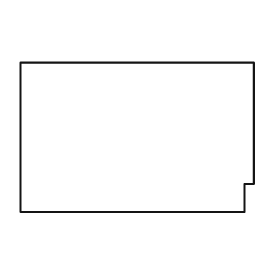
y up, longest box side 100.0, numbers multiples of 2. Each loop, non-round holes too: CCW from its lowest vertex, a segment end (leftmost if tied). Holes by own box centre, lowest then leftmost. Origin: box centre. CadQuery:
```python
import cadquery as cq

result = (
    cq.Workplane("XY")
    .moveTo(-50.0, -32.0)
    .lineTo(46.0, -32.0)
    .lineTo(46.0, -20.0)
    .lineTo(50.0, -20.0)
    .lineTo(50.0, 32.0)
    .lineTo(-50.0, 32.0)
    .close()
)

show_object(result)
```